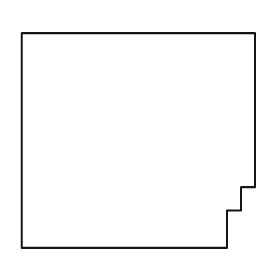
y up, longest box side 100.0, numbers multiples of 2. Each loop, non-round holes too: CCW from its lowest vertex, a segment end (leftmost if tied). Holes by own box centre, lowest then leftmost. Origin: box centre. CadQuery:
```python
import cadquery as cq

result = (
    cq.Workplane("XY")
    .moveTo(-50.0, -46.0)
    .lineTo(38.0, -46.0)
    .lineTo(38.0, -30.0)
    .lineTo(44.0, -30.0)
    .lineTo(44.0, -20.0)
    .lineTo(50.0, -20.0)
    .lineTo(50.0, 46.0)
    .lineTo(-50.0, 46.0)
    .close()
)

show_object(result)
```